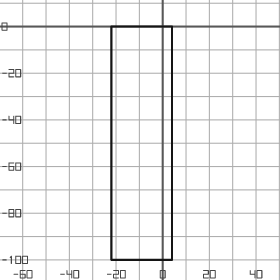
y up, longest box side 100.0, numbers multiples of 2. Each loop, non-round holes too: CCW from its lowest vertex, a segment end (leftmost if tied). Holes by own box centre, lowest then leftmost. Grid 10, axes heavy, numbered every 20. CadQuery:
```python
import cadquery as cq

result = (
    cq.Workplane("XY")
    .moveTo(-22.0, -100.0)
    .lineTo(4.0, -100.0)
    .lineTo(4.0, 0.0)
    .lineTo(-22.0, 0.0)
    .close()
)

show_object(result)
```